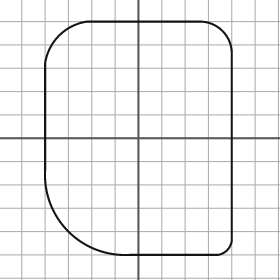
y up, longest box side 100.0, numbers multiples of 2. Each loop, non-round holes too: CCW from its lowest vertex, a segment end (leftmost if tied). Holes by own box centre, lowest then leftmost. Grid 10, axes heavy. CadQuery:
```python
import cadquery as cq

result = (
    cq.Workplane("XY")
    .moveTo(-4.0, -50.0)
    .lineTo(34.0, -50.0)
    .threePointArc((38.0, -48.0), (40.0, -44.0))
    .lineTo(40.0, 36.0)
    .threePointArc((36.0, 46.0), (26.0, 50.0))
    .lineTo(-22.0, 50.0)
    .threePointArc((-34.0, 44.0), (-40.0, 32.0))
    .lineTo(-40.0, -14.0)
    .threePointArc((-30.0, -40.0), (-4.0, -50.0))
    .close()
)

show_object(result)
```